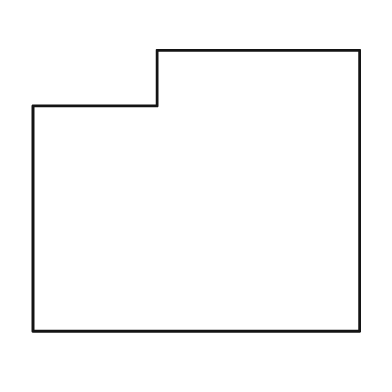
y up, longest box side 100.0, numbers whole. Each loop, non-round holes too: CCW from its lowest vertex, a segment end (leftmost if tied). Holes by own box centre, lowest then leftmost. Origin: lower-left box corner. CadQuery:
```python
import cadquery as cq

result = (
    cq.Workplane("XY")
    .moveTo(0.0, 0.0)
    .lineTo(100.0, 0.0)
    .lineTo(100.0, 86.0)
    .lineTo(38.0, 86.0)
    .lineTo(38.0, 69.0)
    .lineTo(0.0, 69.0)
    .close()
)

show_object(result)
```